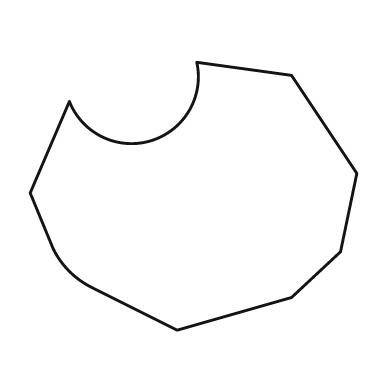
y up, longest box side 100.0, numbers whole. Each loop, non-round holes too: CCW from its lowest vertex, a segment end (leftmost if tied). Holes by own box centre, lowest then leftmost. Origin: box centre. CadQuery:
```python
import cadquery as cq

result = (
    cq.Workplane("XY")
    .moveTo(-5.0, -41.0)
    .lineTo(30.0, -31.0)
    .lineTo(45.0, -17.0)
    .lineTo(50.0, 7.0)
    .lineTo(30.0, 37.0)
    .lineTo(1.0, 41.0)
    .threePointArc((-13.0, 17.0), (-38.0, 29.0))
    .lineTo(-50.0, 1.0)
    .lineTo(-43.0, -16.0)
    .threePointArc((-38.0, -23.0), (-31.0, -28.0))
    .close()
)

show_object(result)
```